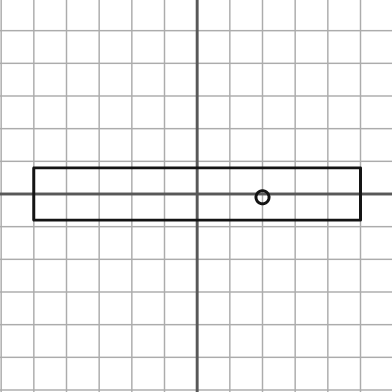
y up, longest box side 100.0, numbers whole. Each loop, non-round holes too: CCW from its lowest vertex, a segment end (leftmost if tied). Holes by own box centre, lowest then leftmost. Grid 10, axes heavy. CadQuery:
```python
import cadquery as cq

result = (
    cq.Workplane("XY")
    .moveTo(-50.0, -8.0)
    .lineTo(50.0, -8.0)
    .lineTo(50.0, 8.0)
    .lineTo(-50.0, 8.0)
    .close()
    .moveTo(20.0, -1.0)
    .circle(2.0)
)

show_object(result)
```